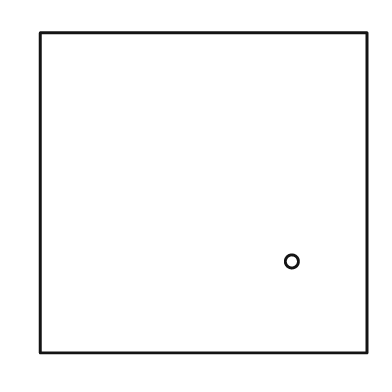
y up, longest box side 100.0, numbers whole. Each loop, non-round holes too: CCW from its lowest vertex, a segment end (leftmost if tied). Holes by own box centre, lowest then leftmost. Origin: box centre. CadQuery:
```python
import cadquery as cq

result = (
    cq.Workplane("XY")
    .moveTo(-50.0, -49.0)
    .lineTo(50.0, -49.0)
    .lineTo(50.0, 49.0)
    .lineTo(-50.0, 49.0)
    .close()
    .moveTo(27.0, -21.0)
    .circle(2.0)
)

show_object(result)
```